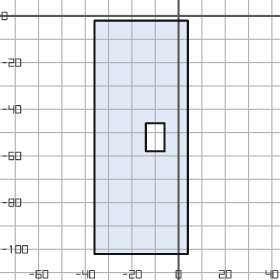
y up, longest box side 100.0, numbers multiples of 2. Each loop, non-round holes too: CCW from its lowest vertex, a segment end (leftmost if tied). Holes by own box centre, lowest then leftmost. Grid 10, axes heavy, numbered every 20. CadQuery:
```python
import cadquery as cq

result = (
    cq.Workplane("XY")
    .moveTo(-36.0, -102.0)
    .lineTo(4.0, -102.0)
    .lineTo(4.0, -2.0)
    .lineTo(-36.0, -2.0)
    .close()
    .moveTo(-14.0, -58.0)
    .lineTo(-6.0, -58.0)
    .lineTo(-6.0, -46.0)
    .lineTo(-14.0, -46.0)
    .close()
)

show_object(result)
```